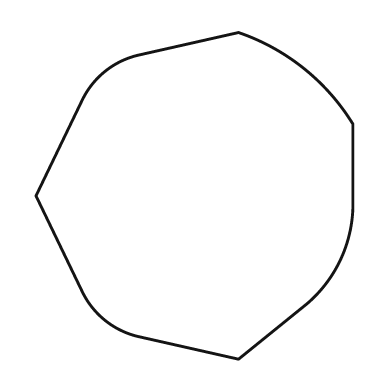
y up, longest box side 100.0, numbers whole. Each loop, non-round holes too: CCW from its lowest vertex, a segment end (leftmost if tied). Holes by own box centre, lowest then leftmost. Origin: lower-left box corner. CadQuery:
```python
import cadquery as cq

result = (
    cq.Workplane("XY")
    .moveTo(62.0, 0.0)
    .lineTo(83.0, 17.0)
    .threePointArc((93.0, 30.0), (97.0, 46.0))
    .lineTo(97.0, 72.0)
    .threePointArc((82.0, 89.0), (62.0, 100.0))
    .lineTo(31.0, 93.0)
    .threePointArc((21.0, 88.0), (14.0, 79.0))
    .lineTo(0.0, 50.0)
    .lineTo(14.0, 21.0)
    .threePointArc((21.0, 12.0), (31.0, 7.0))
    .close()
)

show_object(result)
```